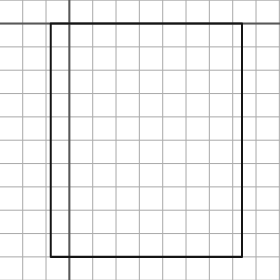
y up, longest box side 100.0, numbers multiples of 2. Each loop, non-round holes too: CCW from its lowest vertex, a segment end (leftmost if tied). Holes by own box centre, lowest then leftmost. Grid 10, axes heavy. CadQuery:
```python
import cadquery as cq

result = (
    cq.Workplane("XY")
    .moveTo(-8.0, -100.0)
    .lineTo(74.0, -100.0)
    .lineTo(74.0, 0.0)
    .lineTo(-8.0, 0.0)
    .close()
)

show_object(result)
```